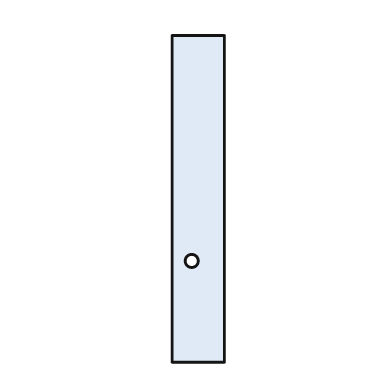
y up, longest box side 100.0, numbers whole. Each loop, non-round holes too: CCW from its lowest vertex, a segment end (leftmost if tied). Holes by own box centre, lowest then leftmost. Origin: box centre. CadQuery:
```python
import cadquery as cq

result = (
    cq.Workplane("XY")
    .moveTo(-8.0, -50.0)
    .lineTo(8.0, -50.0)
    .lineTo(8.0, 50.0)
    .lineTo(-8.0, 50.0)
    .close()
    .moveTo(-2.0, -19.0)
    .circle(2.0)
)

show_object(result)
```